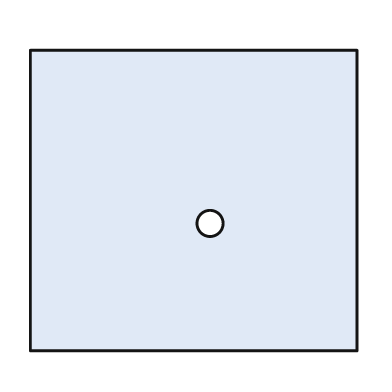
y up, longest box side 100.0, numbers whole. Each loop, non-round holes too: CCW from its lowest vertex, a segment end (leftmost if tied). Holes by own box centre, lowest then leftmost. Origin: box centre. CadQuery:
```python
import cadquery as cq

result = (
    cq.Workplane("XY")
    .moveTo(-50.0, -46.0)
    .lineTo(50.0, -46.0)
    .lineTo(50.0, 46.0)
    .lineTo(-50.0, 46.0)
    .close()
    .moveTo(5.0, -7.0)
    .circle(4.0)
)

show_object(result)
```